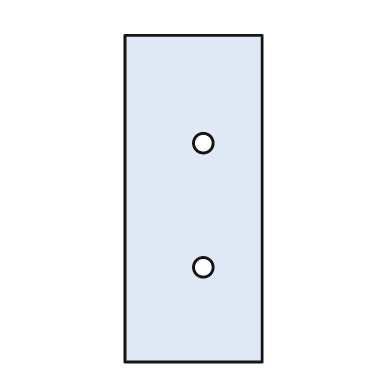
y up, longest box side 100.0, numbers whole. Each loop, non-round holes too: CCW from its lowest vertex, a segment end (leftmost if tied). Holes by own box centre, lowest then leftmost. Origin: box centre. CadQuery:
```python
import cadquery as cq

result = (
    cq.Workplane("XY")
    .moveTo(-21.0, -50.0)
    .lineTo(21.0, -50.0)
    .lineTo(21.0, 50.0)
    .lineTo(-21.0, 50.0)
    .close()
    .moveTo(3.0, -21.0)
    .circle(3.0)
    .moveTo(3.0, 17.0)
    .circle(3.0)
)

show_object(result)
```